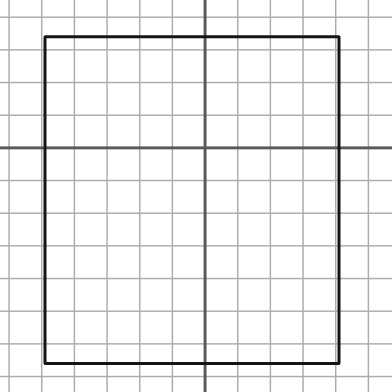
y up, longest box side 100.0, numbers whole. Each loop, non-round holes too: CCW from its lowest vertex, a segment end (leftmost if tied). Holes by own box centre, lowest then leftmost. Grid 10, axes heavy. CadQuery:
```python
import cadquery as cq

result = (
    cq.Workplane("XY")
    .moveTo(-49.0, -66.0)
    .lineTo(41.0, -66.0)
    .lineTo(41.0, 34.0)
    .lineTo(-49.0, 34.0)
    .close()
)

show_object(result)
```